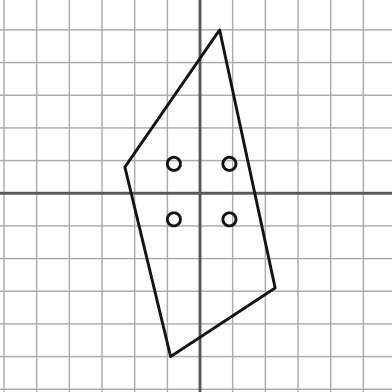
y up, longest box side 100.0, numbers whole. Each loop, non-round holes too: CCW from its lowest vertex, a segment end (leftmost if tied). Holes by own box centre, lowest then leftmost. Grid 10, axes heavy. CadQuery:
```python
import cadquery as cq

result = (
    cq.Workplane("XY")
    .moveTo(-9.0, -50.0)
    .lineTo(23.0, -29.0)
    .lineTo(6.0, 50.0)
    .lineTo(-23.0, 8.0)
    .close()
    .moveTo(-8.0, -8.0)
    .circle(2.0)
    .moveTo(9.0, -8.0)
    .circle(2.0)
    .moveTo(-8.0, 9.0)
    .circle(2.0)
    .moveTo(9.0, 9.0)
    .circle(2.0)
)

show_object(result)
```